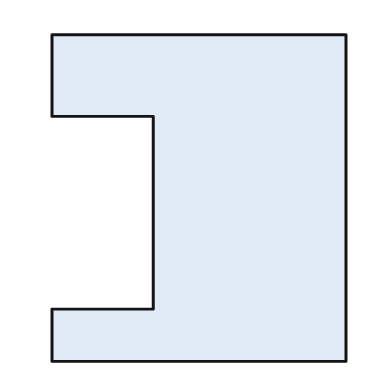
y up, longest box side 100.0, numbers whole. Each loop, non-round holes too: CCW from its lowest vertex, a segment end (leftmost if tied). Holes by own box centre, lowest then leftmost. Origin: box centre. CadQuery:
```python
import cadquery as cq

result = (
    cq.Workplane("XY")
    .moveTo(-45.0, -50.0)
    .lineTo(45.0, -50.0)
    .lineTo(45.0, 50.0)
    .lineTo(-45.0, 50.0)
    .lineTo(-45.0, 25.0)
    .lineTo(-14.0, 25.0)
    .lineTo(-14.0, -34.0)
    .lineTo(-45.0, -34.0)
    .close()
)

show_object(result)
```